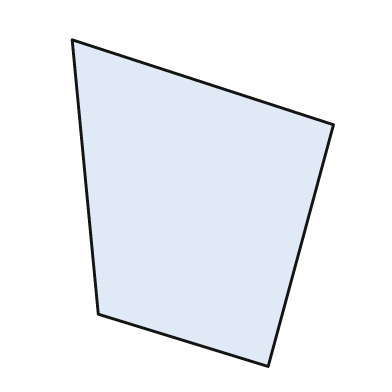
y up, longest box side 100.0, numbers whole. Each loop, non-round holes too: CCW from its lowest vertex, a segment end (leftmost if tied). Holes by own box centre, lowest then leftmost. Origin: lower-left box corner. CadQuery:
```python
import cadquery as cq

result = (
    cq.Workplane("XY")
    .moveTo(60.0, 0.0)
    .lineTo(80.0, 74.0)
    .lineTo(0.0, 100.0)
    .lineTo(8.0, 16.0)
    .close()
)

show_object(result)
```